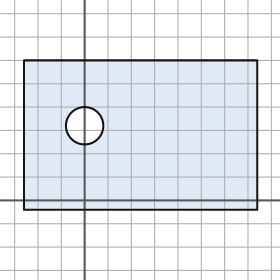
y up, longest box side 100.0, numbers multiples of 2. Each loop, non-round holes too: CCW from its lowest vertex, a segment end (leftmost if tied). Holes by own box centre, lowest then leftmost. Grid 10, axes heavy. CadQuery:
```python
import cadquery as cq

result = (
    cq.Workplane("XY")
    .moveTo(-26.0, -4.0)
    .lineTo(74.0, -4.0)
    .lineTo(74.0, 60.0)
    .lineTo(-26.0, 60.0)
    .close()
    .moveTo(0.0, 32.0)
    .circle(8.0)
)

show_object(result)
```